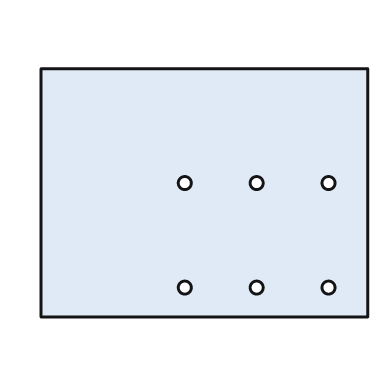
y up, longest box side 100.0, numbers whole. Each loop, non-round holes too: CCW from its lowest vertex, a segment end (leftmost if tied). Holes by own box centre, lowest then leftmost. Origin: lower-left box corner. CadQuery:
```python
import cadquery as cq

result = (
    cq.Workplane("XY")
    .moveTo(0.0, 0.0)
    .lineTo(100.0, 0.0)
    .lineTo(100.0, 76.0)
    .lineTo(0.0, 76.0)
    .close()
    .moveTo(44.0, 9.0)
    .circle(2.0)
    .moveTo(66.0, 9.0)
    .circle(2.0)
    .moveTo(88.0, 9.0)
    .circle(2.0)
    .moveTo(44.0, 41.0)
    .circle(2.0)
    .moveTo(66.0, 41.0)
    .circle(2.0)
    .moveTo(88.0, 41.0)
    .circle(2.0)
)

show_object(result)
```